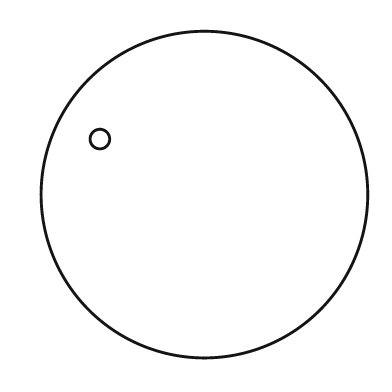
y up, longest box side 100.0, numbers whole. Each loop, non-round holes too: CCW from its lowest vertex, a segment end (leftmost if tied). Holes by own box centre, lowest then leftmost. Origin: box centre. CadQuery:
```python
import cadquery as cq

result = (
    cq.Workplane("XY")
    .moveTo(0.0, 0.0)
    .circle(50.0)
    .moveTo(-32.0, 17.0)
    .circle(3.0)
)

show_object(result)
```